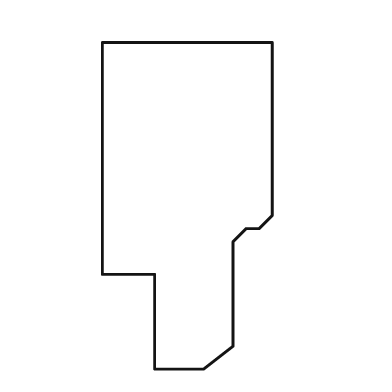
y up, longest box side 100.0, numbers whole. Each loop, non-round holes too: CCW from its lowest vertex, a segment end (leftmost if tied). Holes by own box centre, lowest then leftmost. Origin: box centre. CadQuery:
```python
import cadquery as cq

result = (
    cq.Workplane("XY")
    .moveTo(-10.0, -50.0)
    .lineTo(5.0, -50.0)
    .lineTo(14.0, -43.0)
    .lineTo(14.0, -11.0)
    .lineTo(18.0, -7.0)
    .lineTo(22.0, -7.0)
    .lineTo(26.0, -3.0)
    .lineTo(26.0, 50.0)
    .lineTo(-26.0, 50.0)
    .lineTo(-26.0, -21.0)
    .lineTo(-10.0, -21.0)
    .close()
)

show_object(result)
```